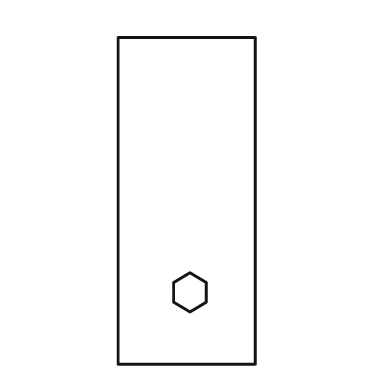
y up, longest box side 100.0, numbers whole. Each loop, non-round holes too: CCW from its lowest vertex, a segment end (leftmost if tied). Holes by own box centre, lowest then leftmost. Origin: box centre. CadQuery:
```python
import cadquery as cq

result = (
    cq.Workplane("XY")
    .moveTo(-21.0, -50.0)
    .lineTo(21.0, -50.0)
    .lineTo(21.0, 50.0)
    .lineTo(-21.0, 50.0)
    .close()
    .moveTo(1.0, -34.0)
    .lineTo(6.0, -31.0)
    .lineTo(6.0, -25.0)
    .lineTo(1.0, -22.0)
    .lineTo(-4.0, -25.0)
    .lineTo(-4.0, -31.0)
    .close()
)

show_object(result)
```